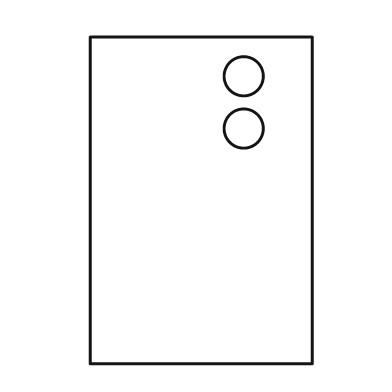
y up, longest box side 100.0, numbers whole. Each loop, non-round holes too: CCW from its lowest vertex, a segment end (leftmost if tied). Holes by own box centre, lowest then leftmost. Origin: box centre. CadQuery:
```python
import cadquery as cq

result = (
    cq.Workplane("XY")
    .moveTo(-34.0, -50.0)
    .lineTo(34.0, -50.0)
    .lineTo(34.0, 50.0)
    .lineTo(-34.0, 50.0)
    .close()
    .moveTo(13.0, 22.0)
    .circle(6.0)
    .moveTo(13.0, 38.0)
    .circle(6.0)
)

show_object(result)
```